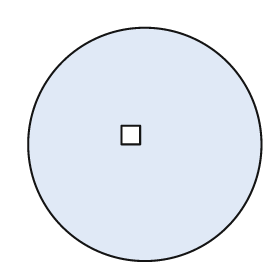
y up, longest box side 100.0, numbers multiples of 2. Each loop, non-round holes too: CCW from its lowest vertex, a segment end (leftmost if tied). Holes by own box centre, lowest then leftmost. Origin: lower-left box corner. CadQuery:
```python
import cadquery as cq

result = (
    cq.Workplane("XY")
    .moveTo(50.0, 50.0)
    .circle(50.0)
    .moveTo(40.0, 50.0)
    .lineTo(48.0, 50.0)
    .lineTo(48.0, 58.0)
    .lineTo(40.0, 58.0)
    .close()
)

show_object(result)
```